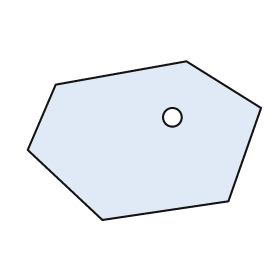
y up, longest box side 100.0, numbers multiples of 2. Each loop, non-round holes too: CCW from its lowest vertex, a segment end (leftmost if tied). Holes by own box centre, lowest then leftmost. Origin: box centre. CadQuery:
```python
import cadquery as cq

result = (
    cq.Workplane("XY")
    .moveTo(-18.0, -34.0)
    .lineTo(36.0, -26.0)
    .lineTo(50.0, 14.0)
    .lineTo(18.0, 34.0)
    .lineTo(-38.0, 24.0)
    .lineTo(-50.0, -4.0)
    .close()
    .moveTo(12.0, 10.0)
    .circle(4.0)
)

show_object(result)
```